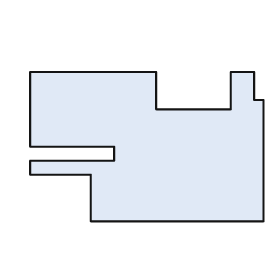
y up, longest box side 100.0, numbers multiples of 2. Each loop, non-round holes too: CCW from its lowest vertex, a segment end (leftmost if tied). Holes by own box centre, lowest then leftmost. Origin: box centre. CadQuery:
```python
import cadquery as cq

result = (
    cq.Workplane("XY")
    .moveTo(-24.0, -32.0)
    .lineTo(50.0, -32.0)
    .lineTo(50.0, 20.0)
    .lineTo(46.0, 20.0)
    .lineTo(46.0, 32.0)
    .lineTo(36.0, 32.0)
    .lineTo(36.0, 16.0)
    .lineTo(4.0, 16.0)
    .lineTo(4.0, 32.0)
    .lineTo(-50.0, 32.0)
    .lineTo(-50.0, 0.0)
    .lineTo(-14.0, 0.0)
    .lineTo(-14.0, -6.0)
    .lineTo(-50.0, -6.0)
    .lineTo(-50.0, -12.0)
    .lineTo(-24.0, -12.0)
    .close()
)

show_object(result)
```